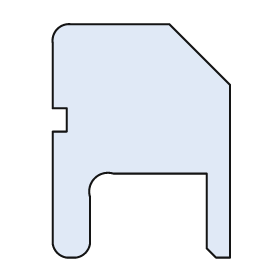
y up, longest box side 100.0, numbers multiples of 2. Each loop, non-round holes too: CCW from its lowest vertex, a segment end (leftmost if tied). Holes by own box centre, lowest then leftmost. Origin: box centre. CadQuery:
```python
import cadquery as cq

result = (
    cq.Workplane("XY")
    .moveTo(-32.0, -50.0)
    .lineTo(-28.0, -50.0)
    .threePointArc((-24.0, -48.0), (-22.0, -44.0))
    .lineTo(-22.0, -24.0)
    .threePointArc((-20.0, -16.0), (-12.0, -14.0))
    .lineTo(28.0, -14.0)
    .lineTo(28.0, -46.0)
    .lineTo(32.0, -50.0)
    .lineTo(38.0, -50.0)
    .lineTo(38.0, 24.0)
    .lineTo(12.0, 50.0)
    .lineTo(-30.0, 50.0)
    .threePointArc((-36.0, 48.0), (-38.0, 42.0))
    .lineTo(-38.0, 14.0)
    .lineTo(-32.0, 14.0)
    .lineTo(-32.0, 4.0)
    .lineTo(-38.0, 4.0)
    .lineTo(-38.0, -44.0)
    .threePointArc((-36.0, -48.0), (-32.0, -50.0))
    .close()
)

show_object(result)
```